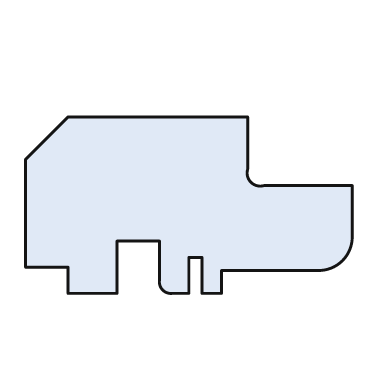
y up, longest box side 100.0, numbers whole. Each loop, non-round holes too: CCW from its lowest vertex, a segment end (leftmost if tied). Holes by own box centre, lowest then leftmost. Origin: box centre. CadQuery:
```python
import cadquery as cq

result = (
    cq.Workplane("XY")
    .moveTo(-37.0, -27.0)
    .lineTo(-22.0, -27.0)
    .lineTo(-22.0, -11.0)
    .lineTo(-9.0, -11.0)
    .lineTo(-9.0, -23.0)
    .threePointArc((-8.0, -26.0), (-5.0, -27.0))
    .lineTo(0.0, -27.0)
    .lineTo(0.0, -16.0)
    .lineTo(4.0, -16.0)
    .lineTo(4.0, -27.0)
    .lineTo(10.0, -27.0)
    .lineTo(10.0, -20.0)
    .lineTo(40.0, -20.0)
    .threePointArc((47.0, -17.0), (50.0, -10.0))
    .lineTo(50.0, 6.0)
    .lineTo(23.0, 6.0)
    .threePointArc((19.0, 7.0), (18.0, 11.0))
    .lineTo(18.0, 27.0)
    .lineTo(-37.0, 27.0)
    .lineTo(-50.0, 14.0)
    .lineTo(-50.0, -19.0)
    .lineTo(-37.0, -19.0)
    .close()
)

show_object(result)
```